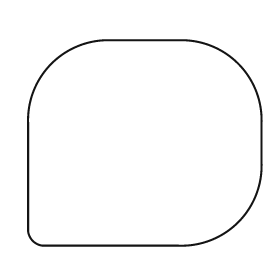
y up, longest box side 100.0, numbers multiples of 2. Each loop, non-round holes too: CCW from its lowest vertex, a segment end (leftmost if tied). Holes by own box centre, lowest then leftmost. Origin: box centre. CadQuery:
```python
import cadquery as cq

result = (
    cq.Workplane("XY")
    .moveTo(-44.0, -44.0)
    .lineTo(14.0, -44.0)
    .threePointArc((40.0, -34.0), (50.0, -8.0))
    .lineTo(50.0, 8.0)
    .threePointArc((40.0, 34.0), (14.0, 44.0))
    .lineTo(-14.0, 44.0)
    .threePointArc((-40.0, 34.0), (-50.0, 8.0))
    .lineTo(-50.0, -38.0)
    .threePointArc((-48.0, -42.0), (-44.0, -44.0))
    .close()
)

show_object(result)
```